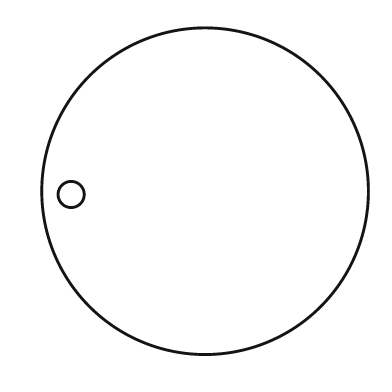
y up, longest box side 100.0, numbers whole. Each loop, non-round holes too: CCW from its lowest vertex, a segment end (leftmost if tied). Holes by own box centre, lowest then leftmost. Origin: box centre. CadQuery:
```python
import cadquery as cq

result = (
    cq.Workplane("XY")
    .moveTo(0.0, 0.0)
    .circle(50.0)
    .moveTo(-41.0, -1.0)
    .circle(4.0)
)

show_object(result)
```